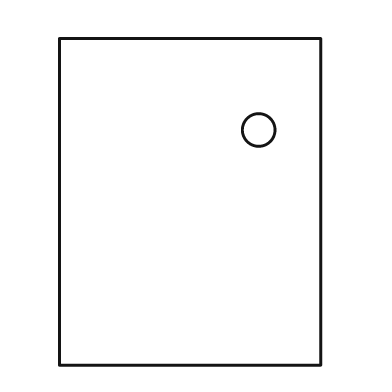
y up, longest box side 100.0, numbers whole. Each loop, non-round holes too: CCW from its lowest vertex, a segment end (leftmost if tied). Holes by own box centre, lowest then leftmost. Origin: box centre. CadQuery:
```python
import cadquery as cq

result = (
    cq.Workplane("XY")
    .moveTo(-40.0, -50.0)
    .lineTo(40.0, -50.0)
    .lineTo(40.0, 50.0)
    .lineTo(-40.0, 50.0)
    .close()
    .moveTo(21.0, 22.0)
    .circle(5.0)
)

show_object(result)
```